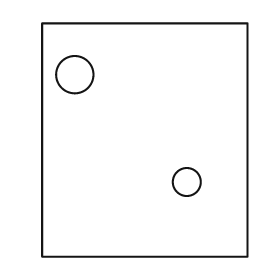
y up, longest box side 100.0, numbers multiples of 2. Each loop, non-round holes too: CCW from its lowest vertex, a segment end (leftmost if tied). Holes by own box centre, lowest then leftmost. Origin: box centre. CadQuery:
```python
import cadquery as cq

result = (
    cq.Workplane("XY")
    .moveTo(-44.0, -50.0)
    .lineTo(44.0, -50.0)
    .lineTo(44.0, 50.0)
    .lineTo(-44.0, 50.0)
    .close()
    .moveTo(18.0, -18.0)
    .circle(6.0)
    .moveTo(-30.0, 28.0)
    .circle(8.0)
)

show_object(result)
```